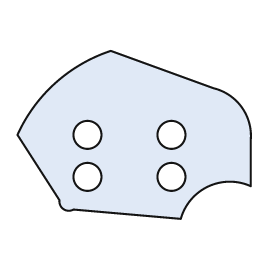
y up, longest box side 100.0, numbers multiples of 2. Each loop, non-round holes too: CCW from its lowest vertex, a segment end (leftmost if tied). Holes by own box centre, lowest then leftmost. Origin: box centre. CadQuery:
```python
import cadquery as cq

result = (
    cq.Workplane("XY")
    .moveTo(20.0, -36.0)
    .threePointArc((32.0, -22.0), (50.0, -22.0))
    .lineTo(50.0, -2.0)
    .threePointArc((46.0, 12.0), (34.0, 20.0))
    .lineTo(-10.0, 36.0)
    .threePointArc((-34.0, 22.0), (-50.0, 0.0))
    .lineTo(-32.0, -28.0)
    .threePointArc((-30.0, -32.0), (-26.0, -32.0))
    .close()
    .moveTo(-20.0, -18.0)
    .circle(6.0)
    .moveTo(16.0, -18.0)
    .circle(6.0)
    .moveTo(-20.0, 0.0)
    .circle(6.0)
    .moveTo(16.0, 0.0)
    .circle(6.0)
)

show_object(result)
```